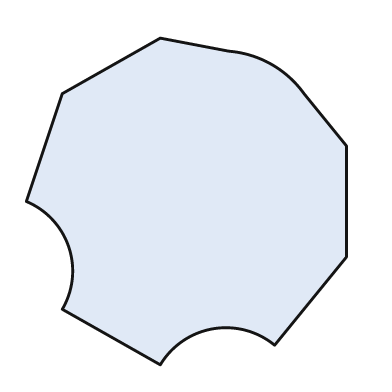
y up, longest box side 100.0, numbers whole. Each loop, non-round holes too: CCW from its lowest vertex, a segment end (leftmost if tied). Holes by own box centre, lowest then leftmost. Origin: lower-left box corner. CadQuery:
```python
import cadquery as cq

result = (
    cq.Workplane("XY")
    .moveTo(41.0, 0.0)
    .threePointArc((57.0, 11.0), (76.0, 6.0))
    .lineTo(98.0, 33.0)
    .lineTo(98.0, 67.0)
    .lineTo(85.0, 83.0)
    .threePointArc((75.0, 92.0), (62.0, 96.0))
    .lineTo(41.0, 100.0)
    .lineTo(11.0, 83.0)
    .lineTo(0.0, 50.0)
    .threePointArc((13.0, 36.0), (11.0, 17.0))
    .close()
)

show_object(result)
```